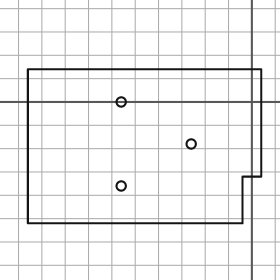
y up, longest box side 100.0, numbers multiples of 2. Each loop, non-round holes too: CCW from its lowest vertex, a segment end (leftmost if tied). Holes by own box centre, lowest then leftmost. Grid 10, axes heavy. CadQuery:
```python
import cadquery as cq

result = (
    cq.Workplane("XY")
    .moveTo(-96.0, -52.0)
    .lineTo(-4.0, -52.0)
    .lineTo(-4.0, -32.0)
    .lineTo(4.0, -32.0)
    .lineTo(4.0, 14.0)
    .lineTo(-96.0, 14.0)
    .close()
    .moveTo(-56.0, -36.0)
    .circle(2.0)
    .moveTo(-26.0, -18.0)
    .circle(2.0)
    .moveTo(-56.0, 0.0)
    .circle(2.0)
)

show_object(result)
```